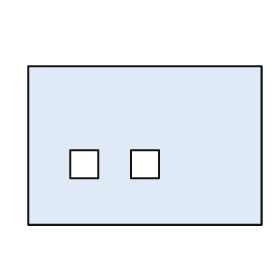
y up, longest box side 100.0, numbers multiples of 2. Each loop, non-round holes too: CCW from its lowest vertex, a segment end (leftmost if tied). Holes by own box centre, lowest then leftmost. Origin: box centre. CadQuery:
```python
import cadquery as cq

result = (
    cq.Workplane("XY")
    .moveTo(-50.0, -34.0)
    .lineTo(50.0, -34.0)
    .lineTo(50.0, 34.0)
    .lineTo(-50.0, 34.0)
    .close()
    .moveTo(-32.0, -14.0)
    .lineTo(-20.0, -14.0)
    .lineTo(-20.0, -2.0)
    .lineTo(-32.0, -2.0)
    .close()
    .moveTo(-6.0, -14.0)
    .lineTo(6.0, -14.0)
    .lineTo(6.0, -2.0)
    .lineTo(-6.0, -2.0)
    .close()
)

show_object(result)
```